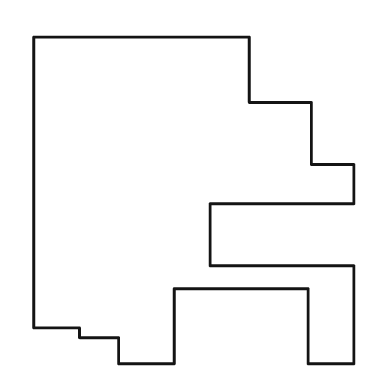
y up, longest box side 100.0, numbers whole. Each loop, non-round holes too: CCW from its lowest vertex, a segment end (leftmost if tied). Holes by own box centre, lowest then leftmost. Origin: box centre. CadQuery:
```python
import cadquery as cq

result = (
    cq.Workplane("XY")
    .moveTo(-23.0, -50.0)
    .lineTo(-6.0, -50.0)
    .lineTo(-6.0, -27.0)
    .lineTo(35.0, -27.0)
    .lineTo(35.0, -50.0)
    .lineTo(49.0, -50.0)
    .lineTo(49.0, -20.0)
    .lineTo(5.0, -20.0)
    .lineTo(5.0, -1.0)
    .lineTo(49.0, -1.0)
    .lineTo(49.0, 11.0)
    .lineTo(36.0, 11.0)
    .lineTo(36.0, 30.0)
    .lineTo(17.0, 30.0)
    .lineTo(17.0, 50.0)
    .lineTo(-49.0, 50.0)
    .lineTo(-49.0, -39.0)
    .lineTo(-35.0, -39.0)
    .lineTo(-35.0, -42.0)
    .lineTo(-23.0, -42.0)
    .close()
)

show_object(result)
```